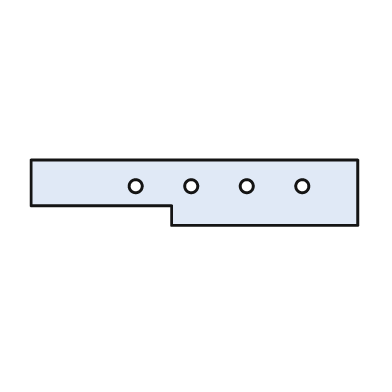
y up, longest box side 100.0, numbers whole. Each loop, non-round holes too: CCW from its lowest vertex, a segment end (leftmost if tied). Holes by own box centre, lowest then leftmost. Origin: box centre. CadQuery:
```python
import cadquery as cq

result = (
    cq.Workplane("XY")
    .moveTo(-7.0, -10.0)
    .lineTo(50.0, -10.0)
    .lineTo(50.0, 10.0)
    .lineTo(-50.0, 10.0)
    .lineTo(-50.0, -4.0)
    .lineTo(-7.0, -4.0)
    .close()
    .moveTo(-18.0, 2.0)
    .circle(2.0)
    .moveTo(-1.0, 2.0)
    .circle(2.0)
    .moveTo(16.0, 2.0)
    .circle(2.0)
    .moveTo(33.0, 2.0)
    .circle(2.0)
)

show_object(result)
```